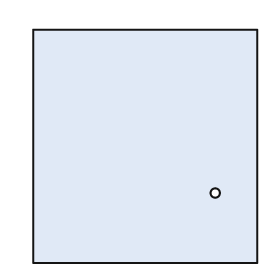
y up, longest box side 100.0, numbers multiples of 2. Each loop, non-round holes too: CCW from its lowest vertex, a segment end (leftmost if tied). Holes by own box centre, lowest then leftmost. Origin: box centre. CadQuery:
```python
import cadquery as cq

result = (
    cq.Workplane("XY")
    .moveTo(-48.0, -50.0)
    .lineTo(48.0, -50.0)
    .lineTo(48.0, 50.0)
    .lineTo(-48.0, 50.0)
    .close()
    .moveTo(30.0, -20.0)
    .circle(2.0)
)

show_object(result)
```